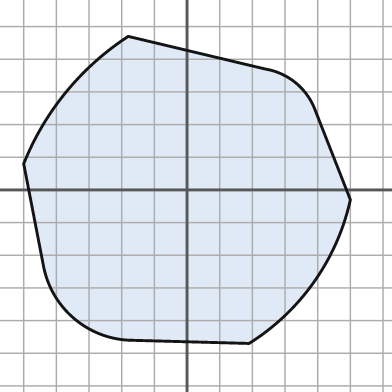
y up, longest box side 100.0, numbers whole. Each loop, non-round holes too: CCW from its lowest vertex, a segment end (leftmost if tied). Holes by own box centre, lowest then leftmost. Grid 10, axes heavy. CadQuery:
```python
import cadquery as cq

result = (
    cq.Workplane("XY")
    .moveTo(19.0, -47.0)
    .threePointArc((39.0, -28.0), (50.0, -3.0))
    .lineTo(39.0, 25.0)
    .threePointArc((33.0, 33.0), (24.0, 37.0))
    .lineTo(-18.0, 47.0)
    .threePointArc((-37.0, 30.0), (-50.0, 8.0))
    .lineTo(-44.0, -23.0)
    .threePointArc((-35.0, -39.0), (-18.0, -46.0))
    .close()
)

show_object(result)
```